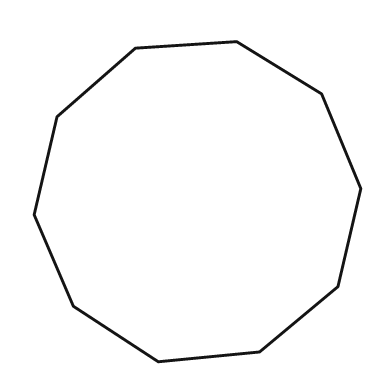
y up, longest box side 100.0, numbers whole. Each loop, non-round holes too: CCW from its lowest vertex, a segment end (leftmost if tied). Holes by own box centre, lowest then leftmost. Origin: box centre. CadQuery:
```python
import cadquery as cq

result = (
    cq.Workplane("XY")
    .moveTo(-12.0, -49.0)
    .lineTo(19.0, -46.0)
    .lineTo(43.0, -26.0)
    .lineTo(50.0, 4.0)
    .lineTo(38.0, 33.0)
    .lineTo(12.0, 49.0)
    .lineTo(-19.0, 47.0)
    .lineTo(-43.0, 26.0)
    .lineTo(-50.0, -4.0)
    .lineTo(-38.0, -32.0)
    .close()
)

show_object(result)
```